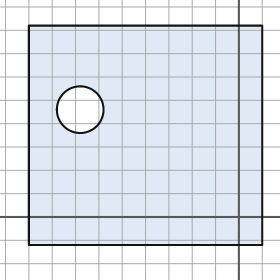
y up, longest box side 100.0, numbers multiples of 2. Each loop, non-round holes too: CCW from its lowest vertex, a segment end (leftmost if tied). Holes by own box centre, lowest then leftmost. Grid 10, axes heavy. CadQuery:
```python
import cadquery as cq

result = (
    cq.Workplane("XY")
    .moveTo(-90.0, -12.0)
    .lineTo(10.0, -12.0)
    .lineTo(10.0, 82.0)
    .lineTo(-90.0, 82.0)
    .close()
    .moveTo(-68.0, 46.0)
    .circle(10.0)
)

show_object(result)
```